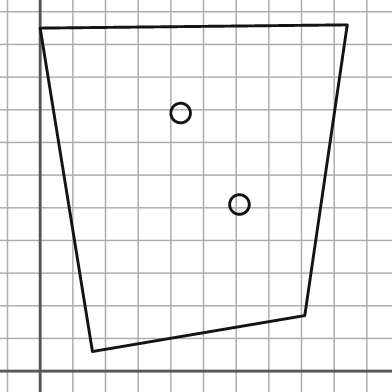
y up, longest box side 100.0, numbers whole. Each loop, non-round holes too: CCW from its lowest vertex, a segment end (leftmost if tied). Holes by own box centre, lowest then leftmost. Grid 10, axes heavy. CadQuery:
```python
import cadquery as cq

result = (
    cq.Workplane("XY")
    .moveTo(16.0, 6.0)
    .lineTo(81.0, 17.0)
    .lineTo(94.0, 106.0)
    .lineTo(0.0, 105.0)
    .close()
    .moveTo(61.0, 51.0)
    .circle(3.0)
    .moveTo(43.0, 79.0)
    .circle(3.0)
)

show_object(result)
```